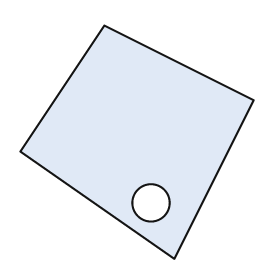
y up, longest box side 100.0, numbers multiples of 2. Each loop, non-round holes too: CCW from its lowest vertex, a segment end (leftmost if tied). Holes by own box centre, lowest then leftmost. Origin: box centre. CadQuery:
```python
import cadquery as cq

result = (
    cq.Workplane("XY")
    .moveTo(16.0, -50.0)
    .lineTo(50.0, 18.0)
    .lineTo(-14.0, 50.0)
    .lineTo(-50.0, -4.0)
    .close()
    .moveTo(6.0, -26.0)
    .circle(8.0)
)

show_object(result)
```